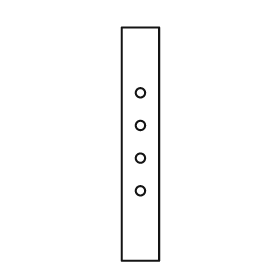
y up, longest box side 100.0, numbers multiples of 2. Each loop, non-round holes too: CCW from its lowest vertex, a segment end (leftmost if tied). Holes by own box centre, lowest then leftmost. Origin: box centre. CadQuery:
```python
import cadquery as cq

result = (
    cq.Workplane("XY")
    .moveTo(-8.0, -50.0)
    .lineTo(8.0, -50.0)
    .lineTo(8.0, 50.0)
    .lineTo(-8.0, 50.0)
    .close()
    .moveTo(0.0, -20.0)
    .circle(2.0)
    .moveTo(0.0, -6.0)
    .circle(2.0)
    .moveTo(0.0, 8.0)
    .circle(2.0)
    .moveTo(0.0, 22.0)
    .circle(2.0)
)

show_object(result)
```